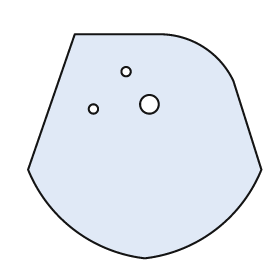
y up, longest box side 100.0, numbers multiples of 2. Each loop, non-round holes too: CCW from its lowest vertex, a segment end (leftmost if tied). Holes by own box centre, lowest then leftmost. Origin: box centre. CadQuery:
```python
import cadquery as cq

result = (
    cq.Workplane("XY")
    .moveTo(0.0, -48.0)
    .threePointArc((30.0, -36.0), (50.0, -10.0))
    .lineTo(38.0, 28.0)
    .threePointArc((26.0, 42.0), (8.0, 48.0))
    .lineTo(-30.0, 48.0)
    .lineTo(-50.0, -10.0)
    .threePointArc((-30.0, -36.0), (0.0, -48.0))
    .close()
    .moveTo(-22.0, 16.0)
    .circle(2.0)
    .moveTo(2.0, 18.0)
    .circle(4.0)
    .moveTo(-8.0, 32.0)
    .circle(2.0)
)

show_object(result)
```